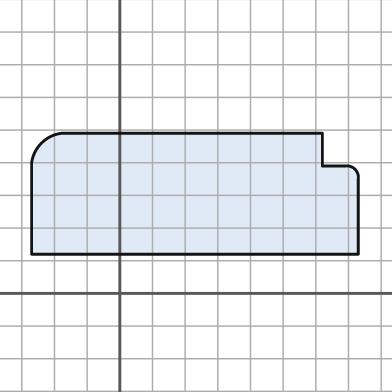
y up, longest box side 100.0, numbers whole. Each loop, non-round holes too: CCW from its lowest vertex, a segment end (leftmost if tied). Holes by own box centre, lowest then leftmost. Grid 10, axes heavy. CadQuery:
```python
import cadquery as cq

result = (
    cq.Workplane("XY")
    .moveTo(-27.0, 12.0)
    .lineTo(73.0, 12.0)
    .lineTo(73.0, 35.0)
    .threePointArc((72.0, 38.0), (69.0, 39.0))
    .lineTo(62.0, 39.0)
    .lineTo(62.0, 49.0)
    .lineTo(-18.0, 49.0)
    .threePointArc((-24.0, 46.0), (-27.0, 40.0))
    .close()
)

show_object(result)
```